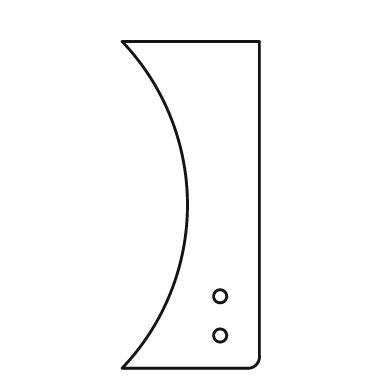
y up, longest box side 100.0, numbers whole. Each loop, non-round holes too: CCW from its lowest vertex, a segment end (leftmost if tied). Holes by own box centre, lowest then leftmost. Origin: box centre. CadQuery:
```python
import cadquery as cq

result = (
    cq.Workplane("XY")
    .moveTo(-21.0, -50.0)
    .lineTo(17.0, -50.0)
    .threePointArc((20.0, -49.0), (21.0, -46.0))
    .lineTo(21.0, 50.0)
    .lineTo(-21.0, 50.0)
    .threePointArc((-1.0, 0.0), (-21.0, -50.0))
    .close()
    .moveTo(9.0, -40.0)
    .circle(2.0)
    .moveTo(9.0, -28.0)
    .circle(2.0)
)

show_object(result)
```